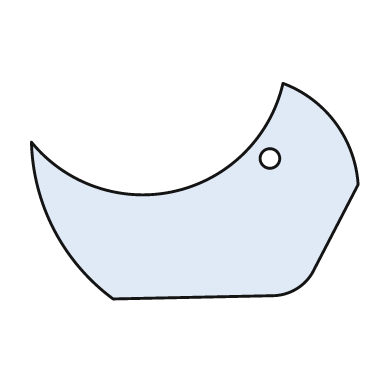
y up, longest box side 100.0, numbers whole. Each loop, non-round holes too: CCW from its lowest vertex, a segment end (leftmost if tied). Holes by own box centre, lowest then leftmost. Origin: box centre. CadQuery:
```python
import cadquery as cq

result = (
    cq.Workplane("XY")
    .moveTo(-25.0, -33.0)
    .lineTo(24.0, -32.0)
    .threePointArc((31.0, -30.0), (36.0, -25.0))
    .lineTo(50.0, 2.0)
    .threePointArc((43.0, 21.0), (27.0, 33.0))
    .threePointArc((-6.0, 0.0), (-50.0, 15.0))
    .threePointArc((-43.0, -12.0), (-25.0, -33.0))
    .close()
    .moveTo(23.0, 10.0)
    .circle(3.0)
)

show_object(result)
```